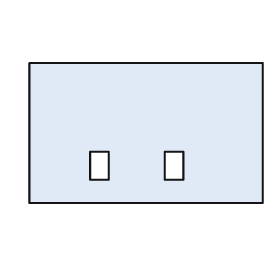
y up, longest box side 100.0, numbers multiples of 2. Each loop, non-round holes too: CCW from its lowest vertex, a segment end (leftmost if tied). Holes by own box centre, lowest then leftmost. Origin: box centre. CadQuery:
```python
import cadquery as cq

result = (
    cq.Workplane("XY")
    .moveTo(-50.0, -30.0)
    .lineTo(50.0, -30.0)
    .lineTo(50.0, 30.0)
    .lineTo(-50.0, 30.0)
    .close()
    .moveTo(-24.0, -20.0)
    .lineTo(-16.0, -20.0)
    .lineTo(-16.0, -8.0)
    .lineTo(-24.0, -8.0)
    .close()
    .moveTo(8.0, -20.0)
    .lineTo(16.0, -20.0)
    .lineTo(16.0, -8.0)
    .lineTo(8.0, -8.0)
    .close()
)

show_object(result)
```